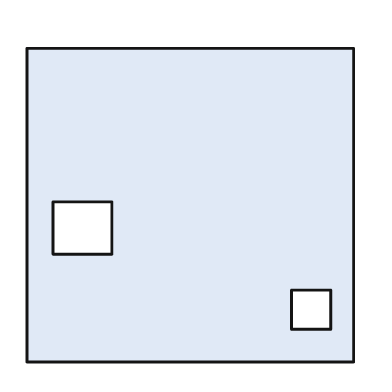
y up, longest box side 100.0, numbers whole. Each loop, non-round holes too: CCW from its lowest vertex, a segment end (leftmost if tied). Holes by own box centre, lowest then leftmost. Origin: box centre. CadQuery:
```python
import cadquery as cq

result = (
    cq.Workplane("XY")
    .moveTo(-50.0, -48.0)
    .lineTo(50.0, -48.0)
    .lineTo(50.0, 48.0)
    .lineTo(-50.0, 48.0)
    .close()
    .moveTo(31.0, -38.0)
    .lineTo(43.0, -38.0)
    .lineTo(43.0, -26.0)
    .lineTo(31.0, -26.0)
    .close()
    .moveTo(-42.0, -15.0)
    .lineTo(-24.0, -15.0)
    .lineTo(-24.0, 1.0)
    .lineTo(-42.0, 1.0)
    .close()
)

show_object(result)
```